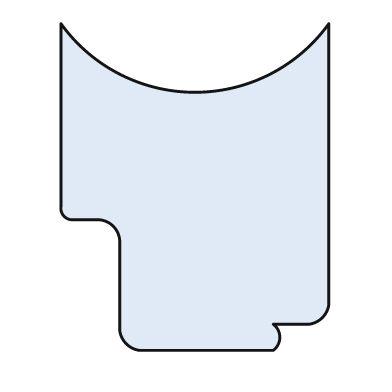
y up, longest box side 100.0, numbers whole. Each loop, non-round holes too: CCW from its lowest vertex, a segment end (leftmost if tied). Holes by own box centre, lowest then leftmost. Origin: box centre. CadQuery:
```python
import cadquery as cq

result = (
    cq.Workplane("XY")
    .moveTo(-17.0, -50.0)
    .lineTo(24.0, -50.0)
    .threePointArc((26.0, -46.0), (24.0, -42.0))
    .lineTo(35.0, -42.0)
    .threePointArc((39.0, -40.0), (41.0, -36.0))
    .lineTo(41.0, 50.0)
    .threePointArc((0.0, 29.0), (-41.0, 50.0))
    .lineTo(-41.0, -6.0)
    .threePointArc((-40.0, -9.0), (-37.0, -10.0))
    .lineTo(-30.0, -10.0)
    .threePointArc((-25.0, -12.0), (-23.0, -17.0))
    .lineTo(-23.0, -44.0)
    .threePointArc((-21.0, -48.0), (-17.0, -50.0))
    .close()
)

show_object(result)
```